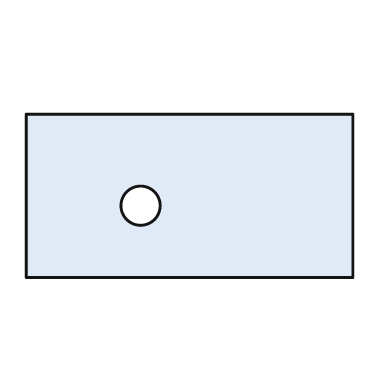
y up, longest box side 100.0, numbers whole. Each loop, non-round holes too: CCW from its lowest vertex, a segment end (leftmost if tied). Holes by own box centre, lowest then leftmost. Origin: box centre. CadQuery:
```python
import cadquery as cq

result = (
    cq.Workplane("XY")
    .moveTo(-50.0, -25.0)
    .lineTo(50.0, -25.0)
    .lineTo(50.0, 25.0)
    .lineTo(-50.0, 25.0)
    .close()
    .moveTo(-15.0, -3.0)
    .circle(6.0)
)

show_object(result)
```